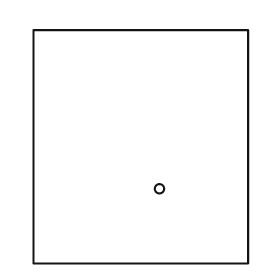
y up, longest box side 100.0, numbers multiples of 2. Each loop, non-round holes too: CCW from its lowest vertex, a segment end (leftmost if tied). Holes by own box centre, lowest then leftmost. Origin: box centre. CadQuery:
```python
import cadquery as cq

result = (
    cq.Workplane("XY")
    .moveTo(-46.0, -50.0)
    .lineTo(46.0, -50.0)
    .lineTo(46.0, 50.0)
    .lineTo(-46.0, 50.0)
    .close()
    .moveTo(8.0, -18.0)
    .circle(2.0)
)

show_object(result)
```